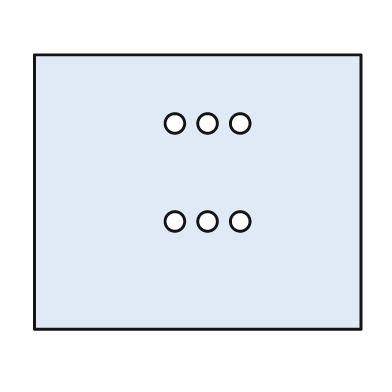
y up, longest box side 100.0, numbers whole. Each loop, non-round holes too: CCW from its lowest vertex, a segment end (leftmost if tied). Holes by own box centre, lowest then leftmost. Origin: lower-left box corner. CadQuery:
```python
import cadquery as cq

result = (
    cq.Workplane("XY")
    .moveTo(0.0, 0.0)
    .lineTo(100.0, 0.0)
    .lineTo(100.0, 84.0)
    .lineTo(0.0, 84.0)
    .close()
    .moveTo(43.0, 33.0)
    .circle(3.0)
    .moveTo(53.0, 33.0)
    .circle(3.0)
    .moveTo(63.0, 33.0)
    .circle(3.0)
    .moveTo(43.0, 63.0)
    .circle(3.0)
    .moveTo(53.0, 63.0)
    .circle(3.0)
    .moveTo(63.0, 63.0)
    .circle(3.0)
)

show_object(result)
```